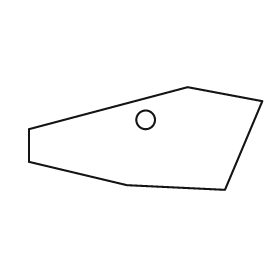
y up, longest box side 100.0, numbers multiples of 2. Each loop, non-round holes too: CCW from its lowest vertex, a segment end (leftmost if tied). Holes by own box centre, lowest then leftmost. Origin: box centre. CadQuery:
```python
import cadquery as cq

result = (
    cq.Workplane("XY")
    .moveTo(34.0, -22.0)
    .lineTo(50.0, 16.0)
    .lineTo(18.0, 22.0)
    .lineTo(-50.0, 4.0)
    .lineTo(-50.0, -10.0)
    .lineTo(-8.0, -20.0)
    .close()
    .moveTo(0.0, 8.0)
    .circle(4.0)
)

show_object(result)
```